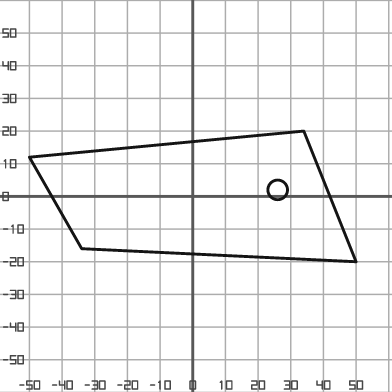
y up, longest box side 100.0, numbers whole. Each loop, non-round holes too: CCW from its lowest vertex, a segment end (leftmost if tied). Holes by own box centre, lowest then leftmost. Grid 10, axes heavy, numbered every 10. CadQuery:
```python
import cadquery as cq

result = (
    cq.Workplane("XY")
    .moveTo(50.0, -20.0)
    .lineTo(34.0, 20.0)
    .lineTo(-50.0, 12.0)
    .lineTo(-34.0, -16.0)
    .close()
    .moveTo(26.0, 2.0)
    .circle(3.0)
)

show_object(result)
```